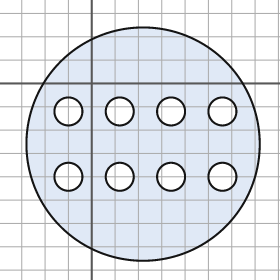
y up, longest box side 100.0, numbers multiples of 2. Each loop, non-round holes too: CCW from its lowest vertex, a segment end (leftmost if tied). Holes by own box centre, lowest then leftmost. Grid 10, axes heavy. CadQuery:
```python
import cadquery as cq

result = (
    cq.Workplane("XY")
    .moveTo(22.0, -26.0)
    .circle(50.0)
    .moveTo(-10.0, -40.0)
    .circle(6.0)
    .moveTo(12.0, -40.0)
    .circle(6.0)
    .moveTo(34.0, -40.0)
    .circle(6.0)
    .moveTo(56.0, -40.0)
    .circle(6.0)
    .moveTo(-10.0, -12.0)
    .circle(6.0)
    .moveTo(12.0, -12.0)
    .circle(6.0)
    .moveTo(34.0, -12.0)
    .circle(6.0)
    .moveTo(56.0, -12.0)
    .circle(6.0)
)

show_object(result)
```